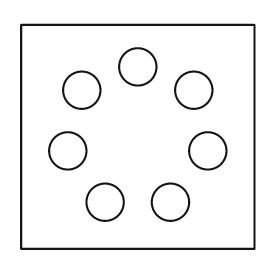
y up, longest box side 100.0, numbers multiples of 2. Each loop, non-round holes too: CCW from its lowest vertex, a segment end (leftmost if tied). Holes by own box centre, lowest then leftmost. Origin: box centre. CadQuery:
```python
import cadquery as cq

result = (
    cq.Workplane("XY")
    .moveTo(-50.0, -48.0)
    .lineTo(50.0, -48.0)
    .lineTo(50.0, 48.0)
    .lineTo(-50.0, 48.0)
    .close()
    .moveTo(-14.0, -28.0)
    .circle(8.0)
    .moveTo(14.0, -28.0)
    .circle(8.0)
    .moveTo(-30.0, -6.0)
    .circle(8.0)
    .moveTo(30.0, -6.0)
    .circle(8.0)
    .moveTo(-24.0, 20.0)
    .circle(8.0)
    .moveTo(24.0, 20.0)
    .circle(8.0)
    .moveTo(0.0, 30.0)
    .circle(8.0)
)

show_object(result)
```